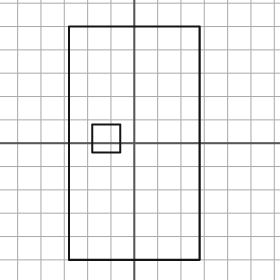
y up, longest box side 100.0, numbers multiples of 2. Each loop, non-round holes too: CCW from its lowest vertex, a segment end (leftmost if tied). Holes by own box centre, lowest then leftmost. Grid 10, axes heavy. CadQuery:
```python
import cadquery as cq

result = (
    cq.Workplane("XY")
    .moveTo(-28.0, -50.0)
    .lineTo(28.0, -50.0)
    .lineTo(28.0, 50.0)
    .lineTo(-28.0, 50.0)
    .close()
    .moveTo(-18.0, -4.0)
    .lineTo(-6.0, -4.0)
    .lineTo(-6.0, 8.0)
    .lineTo(-18.0, 8.0)
    .close()
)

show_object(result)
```